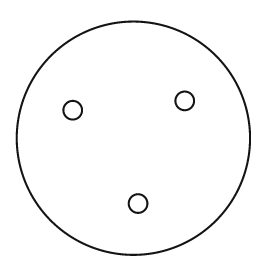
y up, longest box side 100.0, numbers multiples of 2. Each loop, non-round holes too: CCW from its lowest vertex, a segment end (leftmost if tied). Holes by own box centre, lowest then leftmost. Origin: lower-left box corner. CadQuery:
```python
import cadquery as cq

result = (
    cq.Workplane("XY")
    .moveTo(50.0, 50.0)
    .circle(50.0)
    .moveTo(52.0, 22.0)
    .circle(4.0)
    .moveTo(24.0, 62.0)
    .circle(4.0)
    .moveTo(72.0, 66.0)
    .circle(4.0)
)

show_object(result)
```